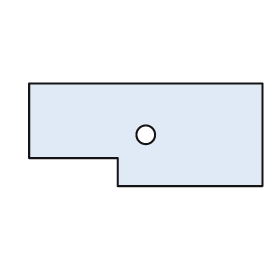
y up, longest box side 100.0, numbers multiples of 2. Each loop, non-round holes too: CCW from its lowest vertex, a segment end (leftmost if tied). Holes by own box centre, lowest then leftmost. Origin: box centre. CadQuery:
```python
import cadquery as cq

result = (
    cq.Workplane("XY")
    .moveTo(-12.0, -22.0)
    .lineTo(50.0, -22.0)
    .lineTo(50.0, 22.0)
    .lineTo(-50.0, 22.0)
    .lineTo(-50.0, -10.0)
    .lineTo(-12.0, -10.0)
    .close()
    .moveTo(0.0, 0.0)
    .circle(4.0)
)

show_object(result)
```